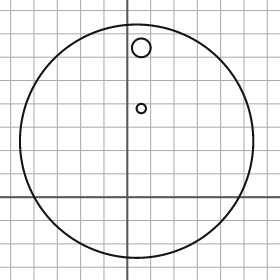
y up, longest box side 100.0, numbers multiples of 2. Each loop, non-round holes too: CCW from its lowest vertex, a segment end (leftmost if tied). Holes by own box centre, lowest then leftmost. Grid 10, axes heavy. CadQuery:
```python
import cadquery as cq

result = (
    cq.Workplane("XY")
    .moveTo(4.0, 24.0)
    .circle(50.0)
    .moveTo(6.0, 38.0)
    .circle(2.0)
    .moveTo(6.0, 64.0)
    .circle(4.0)
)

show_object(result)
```